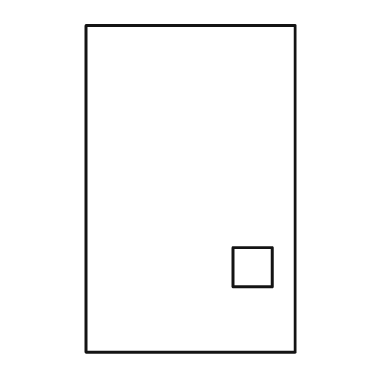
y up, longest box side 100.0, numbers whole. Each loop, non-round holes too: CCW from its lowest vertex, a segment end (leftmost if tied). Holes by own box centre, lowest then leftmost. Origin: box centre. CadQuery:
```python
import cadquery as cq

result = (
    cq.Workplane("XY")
    .moveTo(-32.0, -50.0)
    .lineTo(32.0, -50.0)
    .lineTo(32.0, 50.0)
    .lineTo(-32.0, 50.0)
    .close()
    .moveTo(13.0, -30.0)
    .lineTo(25.0, -30.0)
    .lineTo(25.0, -18.0)
    .lineTo(13.0, -18.0)
    .close()
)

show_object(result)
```